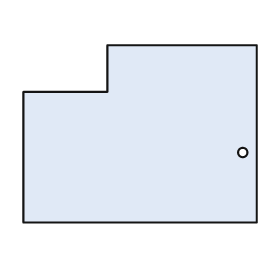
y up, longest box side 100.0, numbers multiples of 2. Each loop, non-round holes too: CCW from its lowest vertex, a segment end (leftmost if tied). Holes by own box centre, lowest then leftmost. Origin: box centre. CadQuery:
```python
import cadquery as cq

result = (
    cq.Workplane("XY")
    .moveTo(-50.0, -38.0)
    .lineTo(50.0, -38.0)
    .lineTo(50.0, 38.0)
    .lineTo(-14.0, 38.0)
    .lineTo(-14.0, 18.0)
    .lineTo(-50.0, 18.0)
    .close()
    .moveTo(44.0, -8.0)
    .circle(2.0)
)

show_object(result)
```